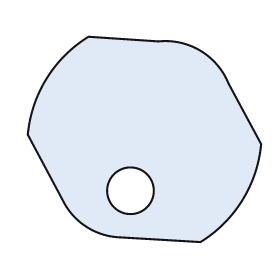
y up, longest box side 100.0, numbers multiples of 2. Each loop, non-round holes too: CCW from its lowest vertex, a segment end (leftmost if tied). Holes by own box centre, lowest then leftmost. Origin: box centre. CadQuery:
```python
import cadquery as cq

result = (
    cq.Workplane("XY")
    .moveTo(24.0, -44.0)
    .threePointArc((42.0, -26.0), (50.0, -2.0))
    .lineTo(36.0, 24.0)
    .threePointArc((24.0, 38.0), (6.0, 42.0))
    .lineTo(-24.0, 44.0)
    .threePointArc((-42.0, 26.0), (-50.0, 2.0))
    .lineTo(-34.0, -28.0)
    .threePointArc((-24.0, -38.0), (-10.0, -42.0))
    .close()
    .moveTo(-6.0, -22.0)
    .circle(10.0)
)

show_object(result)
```